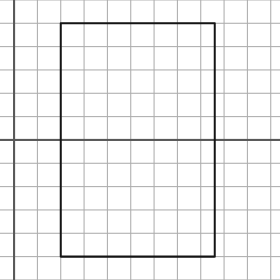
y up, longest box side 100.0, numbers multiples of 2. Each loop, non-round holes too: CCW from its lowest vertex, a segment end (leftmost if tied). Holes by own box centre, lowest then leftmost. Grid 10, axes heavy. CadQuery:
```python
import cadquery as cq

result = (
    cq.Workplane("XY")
    .moveTo(20.0, -50.0)
    .lineTo(86.0, -50.0)
    .lineTo(86.0, 50.0)
    .lineTo(20.0, 50.0)
    .close()
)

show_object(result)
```